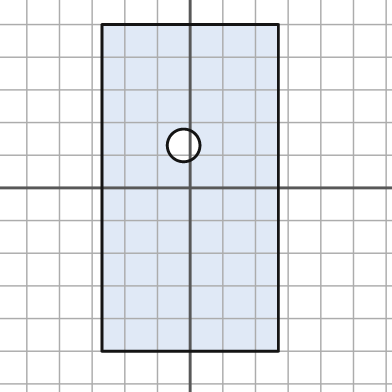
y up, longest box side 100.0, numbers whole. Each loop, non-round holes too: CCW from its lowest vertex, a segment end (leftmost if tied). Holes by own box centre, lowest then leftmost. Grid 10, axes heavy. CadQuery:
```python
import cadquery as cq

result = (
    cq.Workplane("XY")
    .moveTo(-27.0, -50.0)
    .lineTo(27.0, -50.0)
    .lineTo(27.0, 50.0)
    .lineTo(-27.0, 50.0)
    .close()
    .moveTo(-2.0, 13.0)
    .circle(5.0)
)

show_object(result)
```